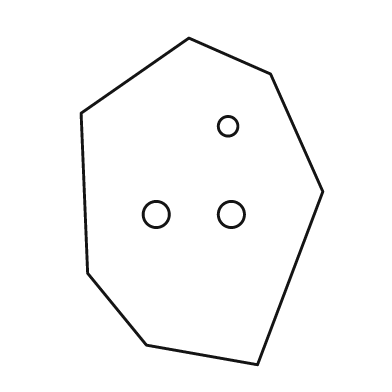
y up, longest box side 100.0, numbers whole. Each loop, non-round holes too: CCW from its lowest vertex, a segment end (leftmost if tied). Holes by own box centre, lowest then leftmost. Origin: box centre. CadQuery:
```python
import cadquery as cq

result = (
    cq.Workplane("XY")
    .moveTo(17.0, -50.0)
    .lineTo(37.0, 3.0)
    .lineTo(21.0, 39.0)
    .lineTo(-4.0, 50.0)
    .lineTo(-37.0, 27.0)
    .lineTo(-35.0, -22.0)
    .lineTo(-17.0, -44.0)
    .close()
    .moveTo(-14.0, -4.0)
    .circle(4.0)
    .moveTo(9.0, -4.0)
    .circle(4.0)
    .moveTo(8.0, 23.0)
    .circle(3.0)
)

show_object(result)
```